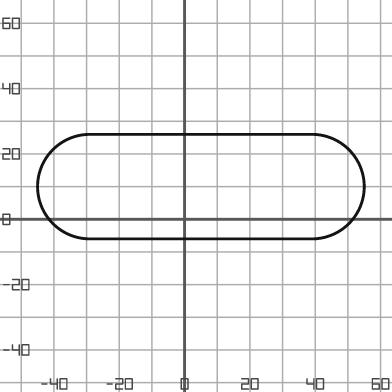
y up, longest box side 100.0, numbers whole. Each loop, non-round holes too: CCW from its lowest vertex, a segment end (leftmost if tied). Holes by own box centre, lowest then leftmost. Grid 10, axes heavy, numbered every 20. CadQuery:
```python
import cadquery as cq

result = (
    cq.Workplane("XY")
    .moveTo(-29.0, -6.0)
    .lineTo(39.0, -6.0)
    .threePointArc((55.0, 10.0), (39.0, 26.0))
    .lineTo(-29.0, 26.0)
    .threePointArc((-45.0, 10.0), (-29.0, -6.0))
    .close()
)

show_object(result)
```